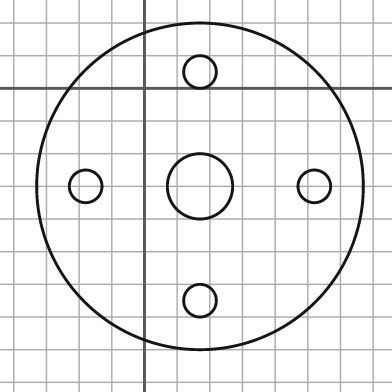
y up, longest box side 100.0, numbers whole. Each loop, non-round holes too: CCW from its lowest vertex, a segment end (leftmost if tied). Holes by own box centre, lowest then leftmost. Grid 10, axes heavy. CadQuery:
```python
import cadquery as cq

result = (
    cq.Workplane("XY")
    .moveTo(17.0, -30.0)
    .circle(50.0)
    .moveTo(17.0, -65.0)
    .circle(5.0)
    .moveTo(-18.0, -30.0)
    .circle(5.0)
    .moveTo(17.0, -30.0)
    .circle(10.0)
    .moveTo(52.0, -30.0)
    .circle(5.0)
    .moveTo(17.0, 5.0)
    .circle(5.0)
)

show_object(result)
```